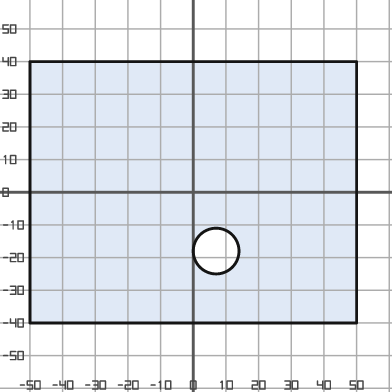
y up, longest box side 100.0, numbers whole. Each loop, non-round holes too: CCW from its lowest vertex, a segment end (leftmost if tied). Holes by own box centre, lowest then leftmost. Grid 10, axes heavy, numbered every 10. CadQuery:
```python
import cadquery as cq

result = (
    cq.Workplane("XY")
    .moveTo(-50.0, -40.0)
    .lineTo(50.0, -40.0)
    .lineTo(50.0, 40.0)
    .lineTo(-50.0, 40.0)
    .close()
    .moveTo(7.0, -18.0)
    .circle(7.0)
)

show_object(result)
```